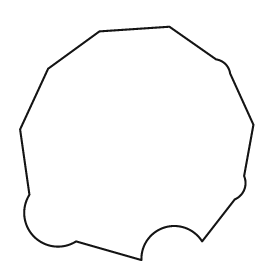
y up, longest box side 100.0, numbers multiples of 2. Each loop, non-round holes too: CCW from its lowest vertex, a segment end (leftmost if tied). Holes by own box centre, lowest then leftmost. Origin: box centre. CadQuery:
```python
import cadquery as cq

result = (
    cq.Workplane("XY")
    .moveTo(2.0, -50.0)
    .threePointArc((12.0, -36.0), (28.0, -42.0))
    .lineTo(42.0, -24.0)
    .threePointArc((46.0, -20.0), (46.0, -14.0))
    .lineTo(50.0, 8.0)
    .lineTo(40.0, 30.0)
    .threePointArc((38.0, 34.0), (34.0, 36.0))
    .lineTo(14.0, 50.0)
    .lineTo(-16.0, 48.0)
    .lineTo(-38.0, 32.0)
    .lineTo(-50.0, 6.0)
    .lineTo(-46.0, -22.0)
    .threePointArc((-44.0, -40.0), (-26.0, -42.0))
    .close()
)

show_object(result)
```